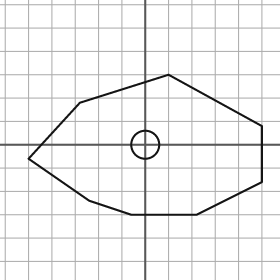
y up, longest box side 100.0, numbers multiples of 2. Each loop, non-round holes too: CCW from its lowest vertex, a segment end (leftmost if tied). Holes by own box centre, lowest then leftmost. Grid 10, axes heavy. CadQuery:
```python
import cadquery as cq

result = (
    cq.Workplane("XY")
    .moveTo(-6.0, -30.0)
    .lineTo(22.0, -30.0)
    .lineTo(50.0, -16.0)
    .lineTo(50.0, 8.0)
    .lineTo(10.0, 30.0)
    .lineTo(-28.0, 18.0)
    .lineTo(-50.0, -6.0)
    .lineTo(-24.0, -24.0)
    .close()
    .moveTo(0.0, 0.0)
    .circle(6.0)
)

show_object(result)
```